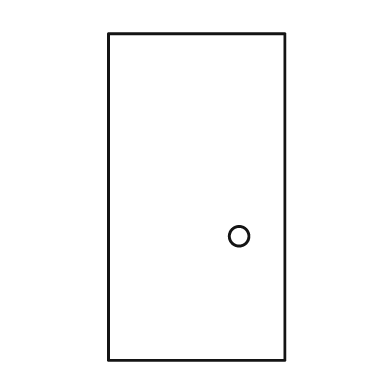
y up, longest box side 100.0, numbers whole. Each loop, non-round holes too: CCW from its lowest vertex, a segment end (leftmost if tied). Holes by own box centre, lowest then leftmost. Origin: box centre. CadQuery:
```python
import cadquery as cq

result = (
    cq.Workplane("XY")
    .moveTo(-27.0, -50.0)
    .lineTo(27.0, -50.0)
    .lineTo(27.0, 50.0)
    .lineTo(-27.0, 50.0)
    .close()
    .moveTo(13.0, -12.0)
    .circle(3.0)
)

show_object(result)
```